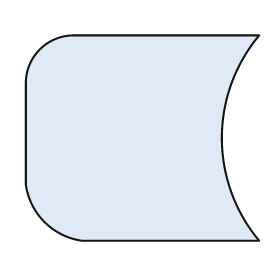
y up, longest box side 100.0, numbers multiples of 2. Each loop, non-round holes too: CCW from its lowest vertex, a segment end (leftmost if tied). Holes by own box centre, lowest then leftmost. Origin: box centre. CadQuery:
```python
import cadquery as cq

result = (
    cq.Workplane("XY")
    .moveTo(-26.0, -44.0)
    .lineTo(50.0, -44.0)
    .threePointArc((34.0, 0.0), (50.0, 44.0))
    .lineTo(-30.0, 44.0)
    .threePointArc((-44.0, 38.0), (-50.0, 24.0))
    .lineTo(-50.0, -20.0)
    .threePointArc((-42.0, -36.0), (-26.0, -44.0))
    .close()
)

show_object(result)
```